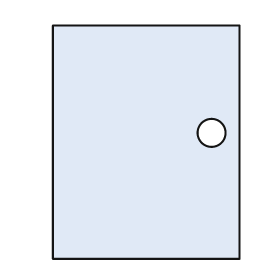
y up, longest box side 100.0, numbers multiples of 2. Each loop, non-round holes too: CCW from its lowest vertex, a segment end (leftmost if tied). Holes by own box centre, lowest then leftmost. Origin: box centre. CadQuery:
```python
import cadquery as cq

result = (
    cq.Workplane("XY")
    .moveTo(-40.0, -50.0)
    .lineTo(40.0, -50.0)
    .lineTo(40.0, 50.0)
    .lineTo(-40.0, 50.0)
    .close()
    .moveTo(28.0, 4.0)
    .circle(6.0)
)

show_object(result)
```